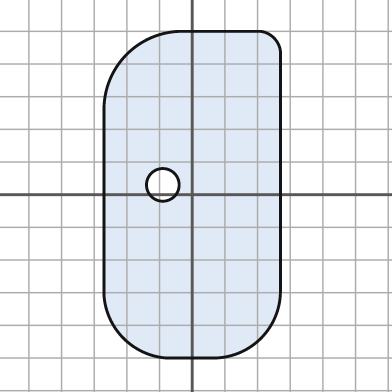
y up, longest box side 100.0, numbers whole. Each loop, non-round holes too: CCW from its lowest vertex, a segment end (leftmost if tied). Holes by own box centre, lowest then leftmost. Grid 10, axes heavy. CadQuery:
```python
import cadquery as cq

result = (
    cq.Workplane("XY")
    .moveTo(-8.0, -50.0)
    .lineTo(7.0, -50.0)
    .threePointArc((21.0, -44.0), (27.0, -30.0))
    .lineTo(27.0, 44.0)
    .threePointArc((25.0, 48.0), (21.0, 50.0))
    .lineTo(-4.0, 50.0)
    .threePointArc((-20.0, 43.0), (-27.0, 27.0))
    .lineTo(-27.0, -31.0)
    .threePointArc((-21.0, -44.0), (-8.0, -50.0))
    .close()
    .moveTo(-9.0, 3.0)
    .circle(5.0)
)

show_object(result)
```